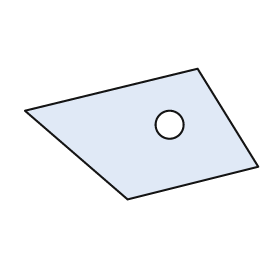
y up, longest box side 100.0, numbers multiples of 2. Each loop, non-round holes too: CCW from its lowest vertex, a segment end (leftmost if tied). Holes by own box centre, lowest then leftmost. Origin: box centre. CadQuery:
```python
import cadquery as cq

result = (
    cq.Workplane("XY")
    .moveTo(-6.0, -28.0)
    .lineTo(50.0, -14.0)
    .lineTo(24.0, 28.0)
    .lineTo(-50.0, 10.0)
    .close()
    .moveTo(12.0, 4.0)
    .circle(6.0)
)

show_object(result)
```